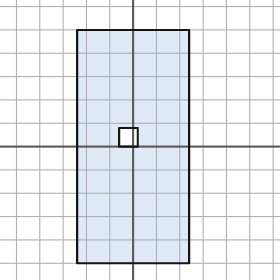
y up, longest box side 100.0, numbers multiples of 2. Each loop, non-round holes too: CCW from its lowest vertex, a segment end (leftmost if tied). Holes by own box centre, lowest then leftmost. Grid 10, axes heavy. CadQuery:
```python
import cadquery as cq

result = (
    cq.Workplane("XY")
    .moveTo(-24.0, -50.0)
    .lineTo(24.0, -50.0)
    .lineTo(24.0, 50.0)
    .lineTo(-24.0, 50.0)
    .close()
    .moveTo(-6.0, 0.0)
    .lineTo(2.0, 0.0)
    .lineTo(2.0, 8.0)
    .lineTo(-6.0, 8.0)
    .close()
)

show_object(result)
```